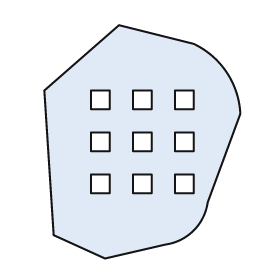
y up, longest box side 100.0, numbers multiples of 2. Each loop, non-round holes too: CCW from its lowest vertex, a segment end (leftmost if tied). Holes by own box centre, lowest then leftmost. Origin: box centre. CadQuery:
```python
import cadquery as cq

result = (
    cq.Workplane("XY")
    .moveTo(-16.0, -50.0)
    .lineTo(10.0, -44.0)
    .threePointArc((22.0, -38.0), (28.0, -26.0))
    .lineTo(42.0, 12.0)
    .threePointArc((36.0, 30.0), (22.0, 42.0))
    .lineTo(-10.0, 50.0)
    .lineTo(-42.0, 22.0)
    .lineTo(-38.0, -40.0)
    .close()
    .moveTo(-22.0, -22.0)
    .lineTo(-14.0, -22.0)
    .lineTo(-14.0, -14.0)
    .lineTo(-22.0, -14.0)
    .close()
    .moveTo(-4.0, -22.0)
    .lineTo(4.0, -22.0)
    .lineTo(4.0, -14.0)
    .lineTo(-4.0, -14.0)
    .close()
    .moveTo(14.0, -22.0)
    .lineTo(22.0, -22.0)
    .lineTo(22.0, -14.0)
    .lineTo(14.0, -14.0)
    .close()
    .moveTo(-22.0, -4.0)
    .lineTo(-14.0, -4.0)
    .lineTo(-14.0, 4.0)
    .lineTo(-22.0, 4.0)
    .close()
    .moveTo(-4.0, -4.0)
    .lineTo(4.0, -4.0)
    .lineTo(4.0, 4.0)
    .lineTo(-4.0, 4.0)
    .close()
    .moveTo(14.0, -4.0)
    .lineTo(22.0, -4.0)
    .lineTo(22.0, 4.0)
    .lineTo(14.0, 4.0)
    .close()
    .moveTo(-22.0, 14.0)
    .lineTo(-14.0, 14.0)
    .lineTo(-14.0, 22.0)
    .lineTo(-22.0, 22.0)
    .close()
    .moveTo(-4.0, 14.0)
    .lineTo(4.0, 14.0)
    .lineTo(4.0, 22.0)
    .lineTo(-4.0, 22.0)
    .close()
    .moveTo(14.0, 14.0)
    .lineTo(22.0, 14.0)
    .lineTo(22.0, 22.0)
    .lineTo(14.0, 22.0)
    .close()
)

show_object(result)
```